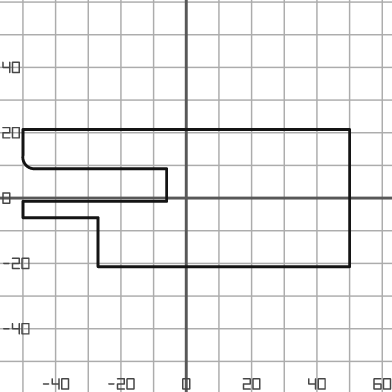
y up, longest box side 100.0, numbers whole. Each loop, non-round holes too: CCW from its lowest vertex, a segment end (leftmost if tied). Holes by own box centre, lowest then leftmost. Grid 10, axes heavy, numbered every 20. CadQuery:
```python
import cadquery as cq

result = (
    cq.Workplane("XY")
    .moveTo(-27.0, -21.0)
    .lineTo(50.0, -21.0)
    .lineTo(50.0, 21.0)
    .lineTo(-50.0, 21.0)
    .lineTo(-50.0, 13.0)
    .threePointArc((-49.0, 10.0), (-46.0, 9.0))
    .lineTo(-6.0, 9.0)
    .lineTo(-6.0, -1.0)
    .lineTo(-50.0, -1.0)
    .lineTo(-50.0, -6.0)
    .lineTo(-27.0, -6.0)
    .close()
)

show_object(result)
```